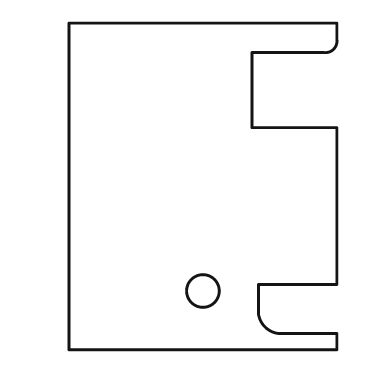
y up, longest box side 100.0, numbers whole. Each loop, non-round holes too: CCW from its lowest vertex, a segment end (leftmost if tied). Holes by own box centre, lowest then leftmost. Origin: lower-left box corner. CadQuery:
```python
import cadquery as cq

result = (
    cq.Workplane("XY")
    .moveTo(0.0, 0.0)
    .lineTo(82.0, 0.0)
    .lineTo(82.0, 5.0)
    .lineTo(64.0, 5.0)
    .threePointArc((60.0, 7.0), (58.0, 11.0))
    .lineTo(58.0, 20.0)
    .lineTo(82.0, 20.0)
    .lineTo(82.0, 68.0)
    .lineTo(56.0, 68.0)
    .lineTo(56.0, 91.0)
    .lineTo(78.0, 91.0)
    .threePointArc((81.0, 92.0), (82.0, 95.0))
    .lineTo(82.0, 100.0)
    .lineTo(0.0, 100.0)
    .close()
    .moveTo(41.0, 18.0)
    .circle(5.0)
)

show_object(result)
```